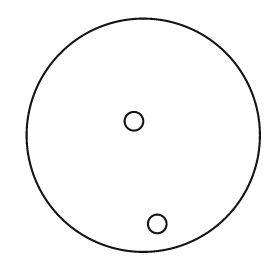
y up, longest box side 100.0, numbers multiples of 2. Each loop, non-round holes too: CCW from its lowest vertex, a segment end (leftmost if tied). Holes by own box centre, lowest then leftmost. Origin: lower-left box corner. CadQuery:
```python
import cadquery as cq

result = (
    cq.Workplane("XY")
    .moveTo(50.0, 50.0)
    .circle(50.0)
    .moveTo(56.0, 12.0)
    .circle(4.0)
    .moveTo(46.0, 56.0)
    .circle(4.0)
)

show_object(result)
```